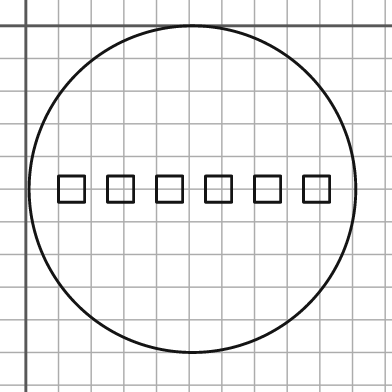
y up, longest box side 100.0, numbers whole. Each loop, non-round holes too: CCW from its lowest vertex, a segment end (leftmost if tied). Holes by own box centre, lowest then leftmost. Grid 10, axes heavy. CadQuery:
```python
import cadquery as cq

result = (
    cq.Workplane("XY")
    .moveTo(51.0, -50.0)
    .circle(50.0)
    .moveTo(10.0, -54.0)
    .lineTo(18.0, -54.0)
    .lineTo(18.0, -46.0)
    .lineTo(10.0, -46.0)
    .close()
    .moveTo(25.0, -54.0)
    .lineTo(33.0, -54.0)
    .lineTo(33.0, -46.0)
    .lineTo(25.0, -46.0)
    .close()
    .moveTo(40.0, -54.0)
    .lineTo(48.0, -54.0)
    .lineTo(48.0, -46.0)
    .lineTo(40.0, -46.0)
    .close()
    .moveTo(55.0, -54.0)
    .lineTo(63.0, -54.0)
    .lineTo(63.0, -46.0)
    .lineTo(55.0, -46.0)
    .close()
    .moveTo(70.0, -54.0)
    .lineTo(78.0, -54.0)
    .lineTo(78.0, -46.0)
    .lineTo(70.0, -46.0)
    .close()
    .moveTo(85.0, -54.0)
    .lineTo(93.0, -54.0)
    .lineTo(93.0, -46.0)
    .lineTo(85.0, -46.0)
    .close()
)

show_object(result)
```